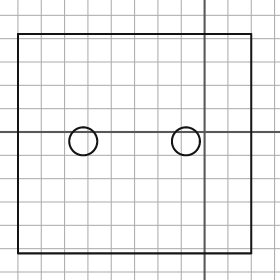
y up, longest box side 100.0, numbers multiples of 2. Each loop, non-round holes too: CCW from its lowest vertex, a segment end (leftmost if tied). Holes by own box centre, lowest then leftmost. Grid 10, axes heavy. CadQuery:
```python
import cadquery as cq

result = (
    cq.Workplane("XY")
    .moveTo(-80.0, -52.0)
    .lineTo(20.0, -52.0)
    .lineTo(20.0, 42.0)
    .lineTo(-80.0, 42.0)
    .close()
    .moveTo(-52.0, -4.0)
    .circle(6.0)
    .moveTo(-8.0, -4.0)
    .circle(6.0)
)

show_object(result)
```